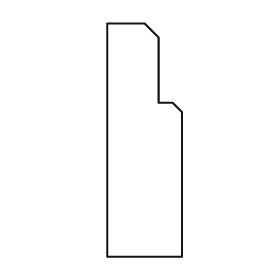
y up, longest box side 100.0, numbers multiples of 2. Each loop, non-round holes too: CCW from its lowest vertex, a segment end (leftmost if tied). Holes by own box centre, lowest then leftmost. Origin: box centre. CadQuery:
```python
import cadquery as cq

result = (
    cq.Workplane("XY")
    .moveTo(-16.0, -50.0)
    .lineTo(16.0, -50.0)
    .lineTo(16.0, 12.0)
    .lineTo(12.0, 16.0)
    .lineTo(6.0, 16.0)
    .lineTo(6.0, 44.0)
    .lineTo(0.0, 50.0)
    .lineTo(-16.0, 50.0)
    .close()
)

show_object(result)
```